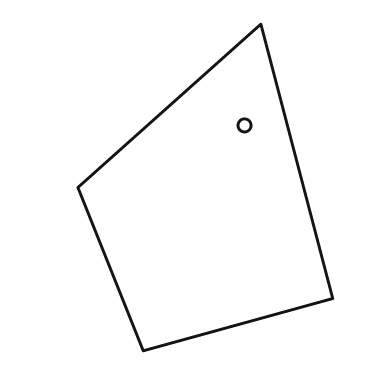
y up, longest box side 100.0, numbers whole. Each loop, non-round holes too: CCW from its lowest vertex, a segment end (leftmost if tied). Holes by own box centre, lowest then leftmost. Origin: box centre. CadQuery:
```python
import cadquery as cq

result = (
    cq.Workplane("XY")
    .moveTo(-19.0, -50.0)
    .lineTo(39.0, -34.0)
    .lineTo(17.0, 50.0)
    .lineTo(-39.0, 0.0)
    .close()
    .moveTo(12.0, 19.0)
    .circle(2.0)
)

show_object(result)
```